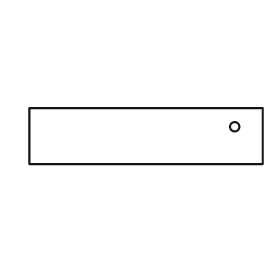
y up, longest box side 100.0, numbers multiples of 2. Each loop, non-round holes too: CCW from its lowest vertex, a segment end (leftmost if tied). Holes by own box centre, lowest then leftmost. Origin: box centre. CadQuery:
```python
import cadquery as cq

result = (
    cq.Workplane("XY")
    .moveTo(-50.0, -12.0)
    .lineTo(50.0, -12.0)
    .lineTo(50.0, 12.0)
    .lineTo(-50.0, 12.0)
    .close()
    .moveTo(38.0, 4.0)
    .circle(2.0)
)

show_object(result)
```